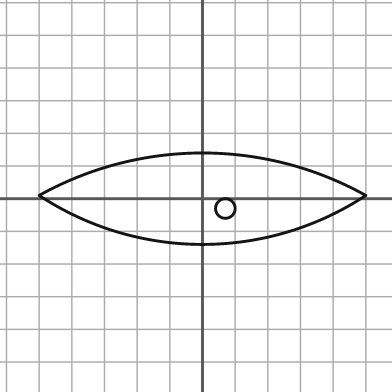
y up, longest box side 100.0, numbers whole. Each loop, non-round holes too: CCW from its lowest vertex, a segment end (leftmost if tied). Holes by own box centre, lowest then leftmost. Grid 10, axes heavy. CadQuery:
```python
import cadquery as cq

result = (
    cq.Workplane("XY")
    .moveTo(-50.0, 1.0)
    .threePointArc((0.0, -14.0), (50.0, 1.0))
    .threePointArc((0.0, 14.0), (-50.0, 1.0))
    .close()
    .moveTo(7.0, -3.0)
    .circle(3.0)
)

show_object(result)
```